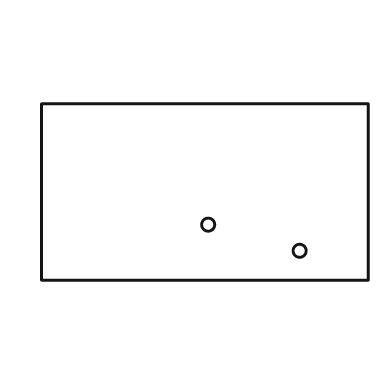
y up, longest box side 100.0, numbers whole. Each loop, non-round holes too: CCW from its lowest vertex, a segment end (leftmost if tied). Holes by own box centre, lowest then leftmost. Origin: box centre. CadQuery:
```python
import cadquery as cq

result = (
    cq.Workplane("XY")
    .moveTo(-50.0, -27.0)
    .lineTo(50.0, -27.0)
    .lineTo(50.0, 27.0)
    .lineTo(-50.0, 27.0)
    .close()
    .moveTo(29.0, -18.0)
    .circle(2.0)
    .moveTo(1.0, -10.0)
    .circle(2.0)
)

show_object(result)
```